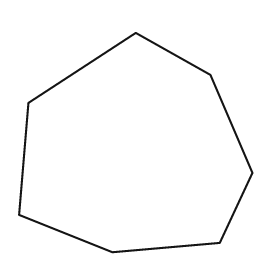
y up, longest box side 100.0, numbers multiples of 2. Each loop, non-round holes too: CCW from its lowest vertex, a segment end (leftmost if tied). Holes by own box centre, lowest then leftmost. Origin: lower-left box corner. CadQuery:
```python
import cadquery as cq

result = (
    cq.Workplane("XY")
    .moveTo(40.0, 0.0)
    .lineTo(86.0, 4.0)
    .lineTo(100.0, 34.0)
    .lineTo(82.0, 76.0)
    .lineTo(50.0, 94.0)
    .lineTo(4.0, 64.0)
    .lineTo(0.0, 16.0)
    .close()
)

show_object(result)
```